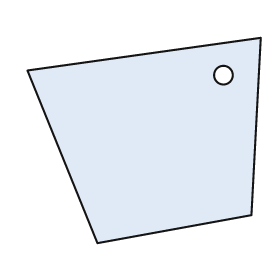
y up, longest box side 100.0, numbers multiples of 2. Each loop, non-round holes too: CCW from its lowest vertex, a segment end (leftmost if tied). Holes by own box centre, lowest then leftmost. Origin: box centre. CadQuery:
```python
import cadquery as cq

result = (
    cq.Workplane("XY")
    .moveTo(-20.0, -44.0)
    .lineTo(46.0, -32.0)
    .lineTo(50.0, 44.0)
    .lineTo(-50.0, 30.0)
    .close()
    .moveTo(34.0, 28.0)
    .circle(4.0)
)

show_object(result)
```